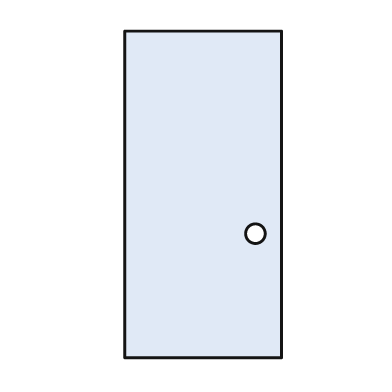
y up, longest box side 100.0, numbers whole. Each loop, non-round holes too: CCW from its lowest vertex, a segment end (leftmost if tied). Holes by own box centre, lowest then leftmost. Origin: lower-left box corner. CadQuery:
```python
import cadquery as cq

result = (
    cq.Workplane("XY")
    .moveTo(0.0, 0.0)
    .lineTo(48.0, 0.0)
    .lineTo(48.0, 100.0)
    .lineTo(0.0, 100.0)
    .close()
    .moveTo(40.0, 38.0)
    .circle(3.0)
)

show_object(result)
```